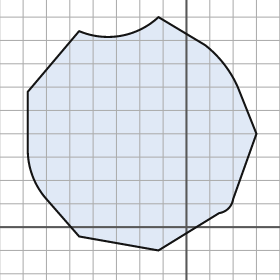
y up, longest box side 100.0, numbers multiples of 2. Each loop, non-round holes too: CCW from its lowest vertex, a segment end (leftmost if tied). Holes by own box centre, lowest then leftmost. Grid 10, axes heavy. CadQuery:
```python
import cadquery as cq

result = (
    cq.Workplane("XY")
    .moveTo(-12.0, -10.0)
    .lineTo(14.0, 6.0)
    .threePointArc((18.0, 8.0), (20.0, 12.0))
    .lineTo(30.0, 40.0)
    .lineTo(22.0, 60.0)
    .threePointArc((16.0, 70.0), (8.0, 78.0))
    .lineTo(-12.0, 90.0)
    .threePointArc((-28.0, 82.0), (-46.0, 84.0))
    .lineTo(-68.0, 58.0)
    .lineTo(-68.0, 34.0)
    .threePointArc((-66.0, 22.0), (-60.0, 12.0))
    .lineTo(-46.0, -4.0)
    .close()
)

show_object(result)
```